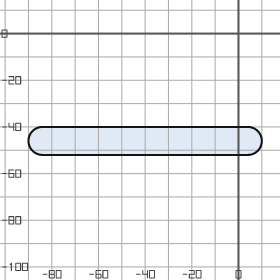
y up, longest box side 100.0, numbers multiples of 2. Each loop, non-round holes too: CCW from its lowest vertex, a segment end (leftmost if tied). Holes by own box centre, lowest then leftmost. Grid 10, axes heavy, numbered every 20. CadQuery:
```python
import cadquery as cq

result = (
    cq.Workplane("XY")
    .moveTo(-84.0, -52.0)
    .lineTo(4.0, -52.0)
    .threePointArc((10.0, -46.0), (4.0, -40.0))
    .lineTo(-84.0, -40.0)
    .threePointArc((-90.0, -46.0), (-84.0, -52.0))
    .close()
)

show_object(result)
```